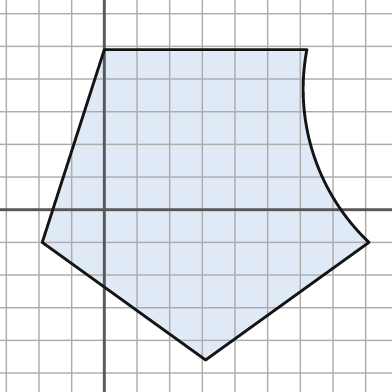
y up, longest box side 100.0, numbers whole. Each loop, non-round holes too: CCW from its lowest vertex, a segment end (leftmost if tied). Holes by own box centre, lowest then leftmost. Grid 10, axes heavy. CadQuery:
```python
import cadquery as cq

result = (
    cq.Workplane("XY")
    .moveTo(31.0, -46.0)
    .lineTo(81.0, -10.0)
    .threePointArc((64.0, 17.0), (62.0, 49.0))
    .lineTo(0.0, 49.0)
    .lineTo(-19.0, -10.0)
    .close()
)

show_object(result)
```